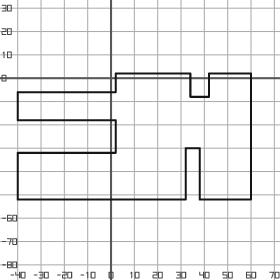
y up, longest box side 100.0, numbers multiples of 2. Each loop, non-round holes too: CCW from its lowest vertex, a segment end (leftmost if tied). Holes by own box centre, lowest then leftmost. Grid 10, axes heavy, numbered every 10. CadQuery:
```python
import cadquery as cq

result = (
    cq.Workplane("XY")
    .moveTo(-40.0, -52.0)
    .lineTo(32.0, -52.0)
    .lineTo(32.0, -30.0)
    .lineTo(38.0, -30.0)
    .lineTo(38.0, -52.0)
    .lineTo(60.0, -52.0)
    .lineTo(60.0, 2.0)
    .lineTo(42.0, 2.0)
    .lineTo(42.0, -8.0)
    .lineTo(34.0, -8.0)
    .lineTo(34.0, 2.0)
    .lineTo(2.0, 2.0)
    .lineTo(2.0, -6.0)
    .lineTo(-40.0, -6.0)
    .lineTo(-40.0, -18.0)
    .lineTo(2.0, -18.0)
    .lineTo(2.0, -32.0)
    .lineTo(-40.0, -32.0)
    .close()
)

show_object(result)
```